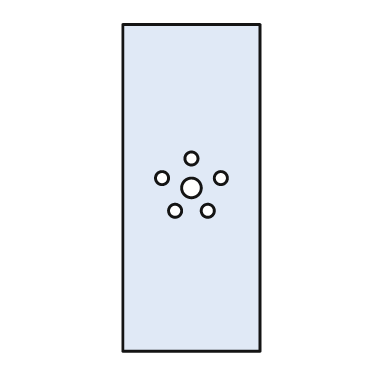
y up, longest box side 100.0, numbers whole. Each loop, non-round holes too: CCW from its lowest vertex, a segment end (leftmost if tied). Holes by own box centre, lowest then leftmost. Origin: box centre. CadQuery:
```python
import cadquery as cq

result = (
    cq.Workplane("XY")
    .moveTo(-21.0, -50.0)
    .lineTo(21.0, -50.0)
    .lineTo(21.0, 50.0)
    .lineTo(-21.0, 50.0)
    .close()
    .moveTo(-5.0, -7.0)
    .circle(2.0)
    .moveTo(5.0, -7.0)
    .circle(2.0)
    .moveTo(0.0, 0.0)
    .circle(3.0)
    .moveTo(-9.0, 3.0)
    .circle(2.0)
    .moveTo(9.0, 3.0)
    .circle(2.0)
    .moveTo(0.0, 9.0)
    .circle(2.0)
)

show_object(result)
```